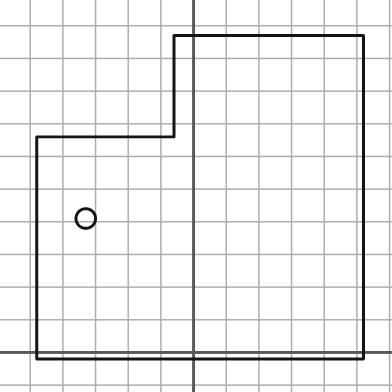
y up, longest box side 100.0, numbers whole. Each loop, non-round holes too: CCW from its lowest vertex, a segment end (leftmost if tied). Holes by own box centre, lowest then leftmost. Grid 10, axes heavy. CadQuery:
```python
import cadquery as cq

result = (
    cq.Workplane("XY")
    .moveTo(-48.0, -2.0)
    .lineTo(52.0, -2.0)
    .lineTo(52.0, 97.0)
    .lineTo(-6.0, 97.0)
    .lineTo(-6.0, 66.0)
    .lineTo(-48.0, 66.0)
    .close()
    .moveTo(-33.0, 41.0)
    .circle(3.0)
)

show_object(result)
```